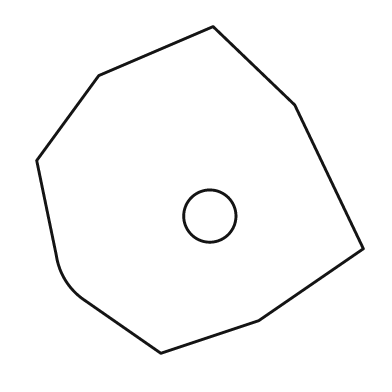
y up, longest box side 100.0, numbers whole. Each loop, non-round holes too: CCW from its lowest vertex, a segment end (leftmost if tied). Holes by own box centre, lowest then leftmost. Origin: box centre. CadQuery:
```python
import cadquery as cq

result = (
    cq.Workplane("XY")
    .moveTo(-12.0, -50.0)
    .lineTo(18.0, -40.0)
    .lineTo(50.0, -18.0)
    .lineTo(29.0, 26.0)
    .lineTo(4.0, 50.0)
    .lineTo(-31.0, 35.0)
    .lineTo(-50.0, 9.0)
    .lineTo(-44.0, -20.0)
    .threePointArc((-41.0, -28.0), (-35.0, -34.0))
    .close()
    .moveTo(3.0, -8.0)
    .circle(8.0)
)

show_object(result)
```